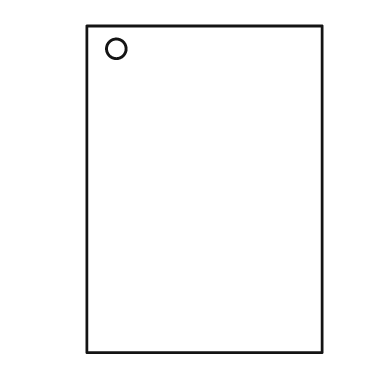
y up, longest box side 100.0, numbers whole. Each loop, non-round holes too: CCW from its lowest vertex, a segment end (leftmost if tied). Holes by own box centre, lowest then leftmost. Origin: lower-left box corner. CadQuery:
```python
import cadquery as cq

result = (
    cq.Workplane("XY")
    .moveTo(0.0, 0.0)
    .lineTo(72.0, 0.0)
    .lineTo(72.0, 100.0)
    .lineTo(0.0, 100.0)
    .close()
    .moveTo(9.0, 93.0)
    .circle(3.0)
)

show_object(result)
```